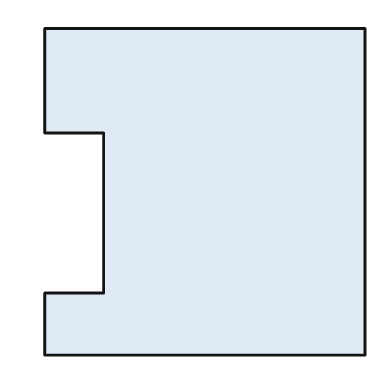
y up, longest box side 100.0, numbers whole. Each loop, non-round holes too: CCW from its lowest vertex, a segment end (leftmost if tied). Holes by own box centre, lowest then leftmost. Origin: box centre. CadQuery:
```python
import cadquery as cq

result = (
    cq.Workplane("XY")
    .moveTo(-49.0, -50.0)
    .lineTo(49.0, -50.0)
    .lineTo(49.0, 50.0)
    .lineTo(-49.0, 50.0)
    .lineTo(-49.0, 18.0)
    .lineTo(-31.0, 18.0)
    .lineTo(-31.0, -31.0)
    .lineTo(-49.0, -31.0)
    .close()
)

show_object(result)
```